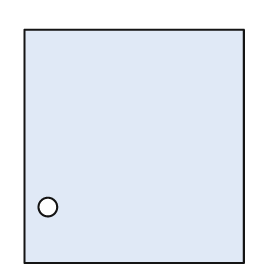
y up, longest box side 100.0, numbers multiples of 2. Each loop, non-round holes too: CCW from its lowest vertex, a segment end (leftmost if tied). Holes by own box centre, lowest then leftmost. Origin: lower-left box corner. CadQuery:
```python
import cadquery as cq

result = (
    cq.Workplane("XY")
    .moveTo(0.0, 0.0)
    .lineTo(94.0, 0.0)
    .lineTo(94.0, 100.0)
    .lineTo(0.0, 100.0)
    .close()
    .moveTo(10.0, 24.0)
    .circle(4.0)
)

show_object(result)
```